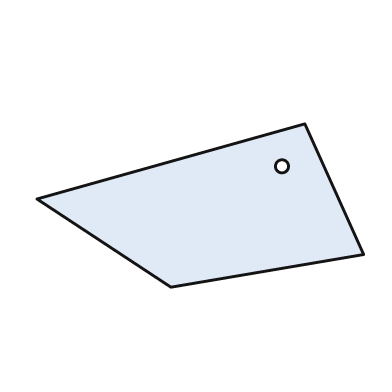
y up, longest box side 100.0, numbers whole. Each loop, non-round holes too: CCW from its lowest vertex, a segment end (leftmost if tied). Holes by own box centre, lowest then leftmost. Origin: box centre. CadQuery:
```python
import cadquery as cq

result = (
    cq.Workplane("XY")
    .moveTo(-9.0, -25.0)
    .lineTo(50.0, -15.0)
    .lineTo(32.0, 25.0)
    .lineTo(-50.0, 2.0)
    .close()
    .moveTo(25.0, 12.0)
    .circle(2.0)
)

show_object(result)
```